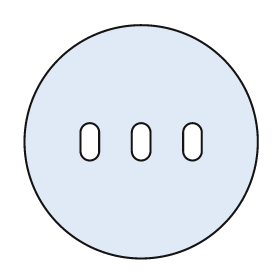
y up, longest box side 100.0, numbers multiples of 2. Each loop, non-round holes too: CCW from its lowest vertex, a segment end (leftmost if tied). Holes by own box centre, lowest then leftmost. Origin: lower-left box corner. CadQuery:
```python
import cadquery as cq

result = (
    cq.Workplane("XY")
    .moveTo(50.0, 50.0)
    .circle(50.0)
    .moveTo(24.0, 46.0)
    .threePointArc((28.0, 42.0), (32.0, 46.0))
    .lineTo(32.0, 54.0)
    .threePointArc((28.0, 58.0), (24.0, 54.0))
    .close()
    .moveTo(46.0, 46.0)
    .threePointArc((50.0, 42.0), (54.0, 46.0))
    .lineTo(54.0, 54.0)
    .threePointArc((50.0, 58.0), (46.0, 54.0))
    .close()
    .moveTo(68.0, 46.0)
    .threePointArc((72.0, 42.0), (76.0, 46.0))
    .lineTo(76.0, 54.0)
    .threePointArc((72.0, 58.0), (68.0, 54.0))
    .close()
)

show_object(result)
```